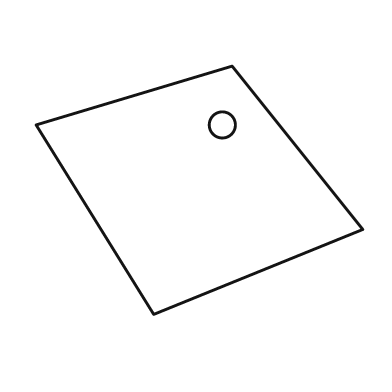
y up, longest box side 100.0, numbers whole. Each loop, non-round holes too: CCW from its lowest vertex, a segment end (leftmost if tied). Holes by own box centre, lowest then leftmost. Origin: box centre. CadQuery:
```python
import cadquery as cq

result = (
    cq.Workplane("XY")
    .moveTo(-14.0, -38.0)
    .lineTo(50.0, -12.0)
    .lineTo(10.0, 38.0)
    .lineTo(-50.0, 20.0)
    .close()
    .moveTo(7.0, 20.0)
    .circle(4.0)
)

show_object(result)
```